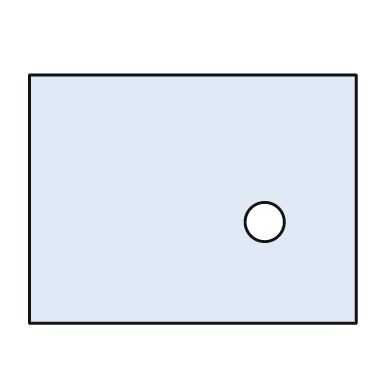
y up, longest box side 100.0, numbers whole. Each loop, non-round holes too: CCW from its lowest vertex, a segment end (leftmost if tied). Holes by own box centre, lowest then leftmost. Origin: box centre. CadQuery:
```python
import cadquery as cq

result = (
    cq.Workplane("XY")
    .moveTo(-50.0, -38.0)
    .lineTo(50.0, -38.0)
    .lineTo(50.0, 38.0)
    .lineTo(-50.0, 38.0)
    .close()
    .moveTo(22.0, -7.0)
    .circle(6.0)
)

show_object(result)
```